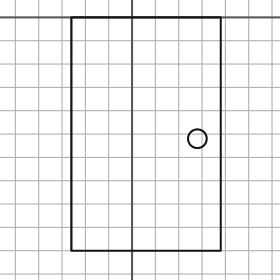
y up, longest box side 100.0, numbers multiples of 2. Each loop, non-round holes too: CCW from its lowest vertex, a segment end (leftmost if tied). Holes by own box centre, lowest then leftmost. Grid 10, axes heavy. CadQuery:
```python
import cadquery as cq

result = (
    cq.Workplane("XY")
    .moveTo(-26.0, -100.0)
    .lineTo(38.0, -100.0)
    .lineTo(38.0, 0.0)
    .lineTo(-26.0, 0.0)
    .close()
    .moveTo(28.0, -52.0)
    .circle(4.0)
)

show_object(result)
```